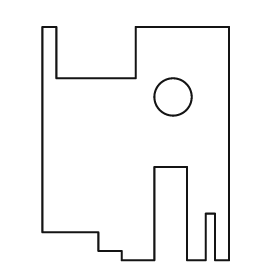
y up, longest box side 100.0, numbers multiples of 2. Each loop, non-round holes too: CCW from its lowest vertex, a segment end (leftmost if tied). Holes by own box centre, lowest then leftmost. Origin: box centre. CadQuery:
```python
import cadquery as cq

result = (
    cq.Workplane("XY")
    .moveTo(-6.0, -50.0)
    .lineTo(8.0, -50.0)
    .lineTo(8.0, -10.0)
    .lineTo(22.0, -10.0)
    .lineTo(22.0, -50.0)
    .lineTo(30.0, -50.0)
    .lineTo(30.0, -30.0)
    .lineTo(34.0, -30.0)
    .lineTo(34.0, -50.0)
    .lineTo(40.0, -50.0)
    .lineTo(40.0, 50.0)
    .lineTo(0.0, 50.0)
    .lineTo(0.0, 28.0)
    .lineTo(-34.0, 28.0)
    .lineTo(-34.0, 50.0)
    .lineTo(-40.0, 50.0)
    .lineTo(-40.0, -38.0)
    .lineTo(-16.0, -38.0)
    .lineTo(-16.0, -46.0)
    .lineTo(-6.0, -46.0)
    .close()
    .moveTo(16.0, 20.0)
    .circle(8.0)
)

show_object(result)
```